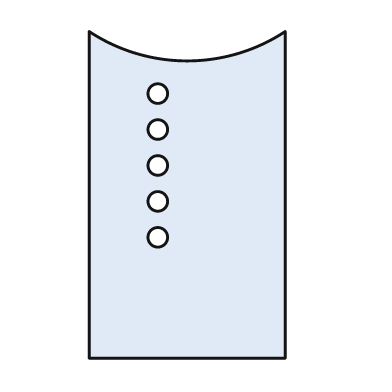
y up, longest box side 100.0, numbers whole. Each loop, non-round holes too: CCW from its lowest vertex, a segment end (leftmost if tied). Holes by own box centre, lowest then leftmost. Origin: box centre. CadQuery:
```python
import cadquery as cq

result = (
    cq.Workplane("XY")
    .moveTo(-30.0, -50.0)
    .lineTo(30.0, -50.0)
    .lineTo(30.0, 50.0)
    .threePointArc((0.0, 41.0), (-30.0, 50.0))
    .close()
    .moveTo(-9.0, -13.0)
    .circle(3.0)
    .moveTo(-9.0, -2.0)
    .circle(3.0)
    .moveTo(-9.0, 9.0)
    .circle(3.0)
    .moveTo(-9.0, 20.0)
    .circle(3.0)
    .moveTo(-9.0, 31.0)
    .circle(3.0)
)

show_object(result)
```